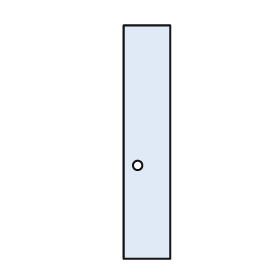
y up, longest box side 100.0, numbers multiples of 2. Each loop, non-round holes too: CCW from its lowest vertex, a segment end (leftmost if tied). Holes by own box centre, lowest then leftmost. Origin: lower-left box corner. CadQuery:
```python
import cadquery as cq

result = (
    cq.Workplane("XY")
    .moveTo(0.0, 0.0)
    .lineTo(20.0, 0.0)
    .lineTo(20.0, 100.0)
    .lineTo(0.0, 100.0)
    .close()
    .moveTo(6.0, 40.0)
    .circle(2.0)
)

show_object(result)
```